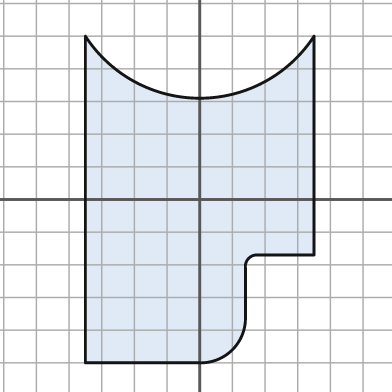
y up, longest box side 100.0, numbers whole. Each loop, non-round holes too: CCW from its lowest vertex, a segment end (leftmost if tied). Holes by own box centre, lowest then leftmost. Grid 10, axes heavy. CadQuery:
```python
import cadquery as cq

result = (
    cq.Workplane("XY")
    .moveTo(-35.0, -50.0)
    .lineTo(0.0, -50.0)
    .threePointArc((10.0, -46.0), (14.0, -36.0))
    .lineTo(14.0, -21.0)
    .threePointArc((15.0, -18.0), (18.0, -17.0))
    .lineTo(35.0, -17.0)
    .lineTo(35.0, 50.0)
    .threePointArc((0.0, 31.0), (-35.0, 50.0))
    .close()
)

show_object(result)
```